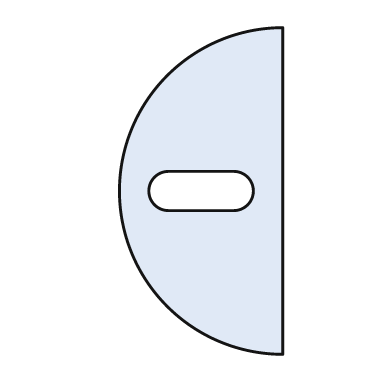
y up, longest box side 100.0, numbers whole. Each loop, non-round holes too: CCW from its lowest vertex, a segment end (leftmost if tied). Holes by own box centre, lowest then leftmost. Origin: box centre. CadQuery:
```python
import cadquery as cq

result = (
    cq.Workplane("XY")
    .moveTo(25.0, -50.0)
    .lineTo(25.0, 50.0)
    .threePointArc((-25.0, 0.0), (25.0, -50.0))
    .close()
    .moveTo(-10.0, -6.0)
    .lineTo(10.0, -6.0)
    .threePointArc((16.0, 0.0), (10.0, 6.0))
    .lineTo(-10.0, 6.0)
    .threePointArc((-16.0, 0.0), (-10.0, -6.0))
    .close()
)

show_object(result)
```